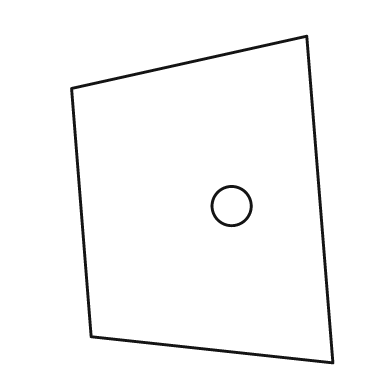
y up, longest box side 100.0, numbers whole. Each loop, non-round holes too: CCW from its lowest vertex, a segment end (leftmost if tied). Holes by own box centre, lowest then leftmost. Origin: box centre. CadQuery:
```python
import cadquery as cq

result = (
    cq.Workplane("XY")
    .moveTo(40.0, -50.0)
    .lineTo(32.0, 50.0)
    .lineTo(-40.0, 34.0)
    .lineTo(-34.0, -42.0)
    .close()
    .moveTo(9.0, -2.0)
    .circle(6.0)
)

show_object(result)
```